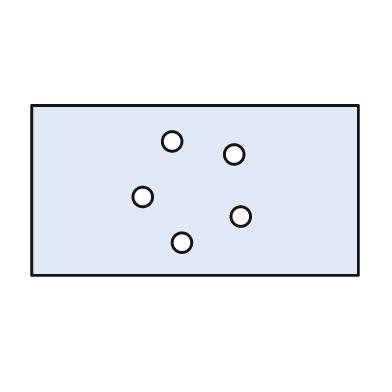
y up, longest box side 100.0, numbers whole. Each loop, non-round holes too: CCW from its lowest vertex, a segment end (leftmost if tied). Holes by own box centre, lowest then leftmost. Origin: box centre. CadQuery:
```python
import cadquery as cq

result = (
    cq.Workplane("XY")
    .moveTo(-50.0, -26.0)
    .lineTo(50.0, -26.0)
    .lineTo(50.0, 26.0)
    .lineTo(-50.0, 26.0)
    .close()
    .moveTo(-4.0, -16.0)
    .circle(3.0)
    .moveTo(14.0, -8.0)
    .circle(3.0)
    .moveTo(-16.0, -2.0)
    .circle(3.0)
    .moveTo(12.0, 11.0)
    .circle(3.0)
    .moveTo(-7.0, 15.0)
    .circle(3.0)
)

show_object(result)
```